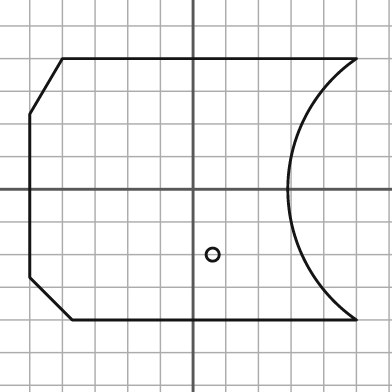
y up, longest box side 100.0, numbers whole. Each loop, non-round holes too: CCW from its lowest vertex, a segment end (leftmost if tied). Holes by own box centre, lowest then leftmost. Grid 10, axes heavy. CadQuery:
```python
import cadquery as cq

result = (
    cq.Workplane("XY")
    .moveTo(-37.0, -40.0)
    .lineTo(50.0, -40.0)
    .threePointArc((29.0, 0.0), (50.0, 40.0))
    .lineTo(-40.0, 40.0)
    .lineTo(-50.0, 23.0)
    .lineTo(-50.0, -27.0)
    .close()
    .moveTo(6.0, -20.0)
    .circle(2.0)
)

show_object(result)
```